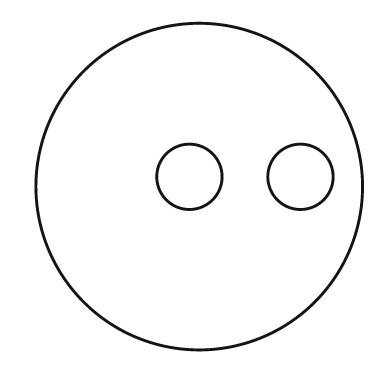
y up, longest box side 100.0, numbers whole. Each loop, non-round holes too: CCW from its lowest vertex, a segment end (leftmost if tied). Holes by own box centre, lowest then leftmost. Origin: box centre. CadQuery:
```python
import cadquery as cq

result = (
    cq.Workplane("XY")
    .moveTo(0.0, 0.0)
    .circle(50.0)
    .moveTo(-3.0, 3.0)
    .circle(10.0)
    .moveTo(31.0, 3.0)
    .circle(10.0)
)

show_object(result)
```